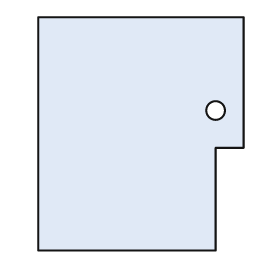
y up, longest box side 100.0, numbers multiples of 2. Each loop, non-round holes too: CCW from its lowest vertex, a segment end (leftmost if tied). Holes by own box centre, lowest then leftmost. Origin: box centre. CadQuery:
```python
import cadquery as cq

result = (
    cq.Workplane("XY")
    .moveTo(-44.0, -50.0)
    .lineTo(32.0, -50.0)
    .lineTo(32.0, -6.0)
    .lineTo(44.0, -6.0)
    .lineTo(44.0, 50.0)
    .lineTo(-44.0, 50.0)
    .close()
    .moveTo(32.0, 10.0)
    .circle(4.0)
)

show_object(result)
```